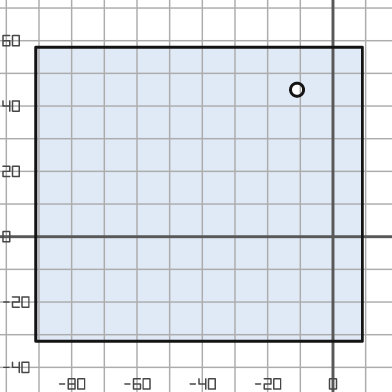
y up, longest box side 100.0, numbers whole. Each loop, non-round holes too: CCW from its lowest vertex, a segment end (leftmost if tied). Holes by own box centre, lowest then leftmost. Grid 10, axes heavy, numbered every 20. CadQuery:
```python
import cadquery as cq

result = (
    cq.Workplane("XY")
    .moveTo(-91.0, -32.0)
    .lineTo(9.0, -32.0)
    .lineTo(9.0, 58.0)
    .lineTo(-91.0, 58.0)
    .close()
    .moveTo(-11.0, 45.0)
    .circle(2.0)
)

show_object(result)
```